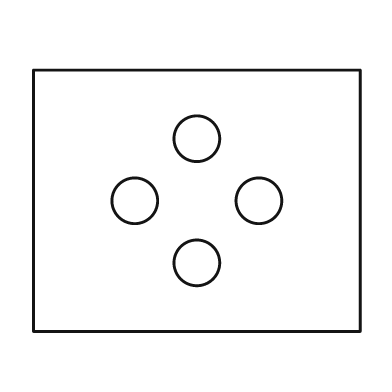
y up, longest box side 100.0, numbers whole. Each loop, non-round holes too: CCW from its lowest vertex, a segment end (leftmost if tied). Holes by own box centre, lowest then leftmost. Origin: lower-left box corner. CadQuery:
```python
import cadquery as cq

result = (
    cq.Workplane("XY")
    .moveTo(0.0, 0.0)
    .lineTo(100.0, 0.0)
    .lineTo(100.0, 80.0)
    .lineTo(0.0, 80.0)
    .close()
    .moveTo(50.0, 21.0)
    .circle(7.0)
    .moveTo(31.0, 40.0)
    .circle(7.0)
    .moveTo(69.0, 40.0)
    .circle(7.0)
    .moveTo(50.0, 59.0)
    .circle(7.0)
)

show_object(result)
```